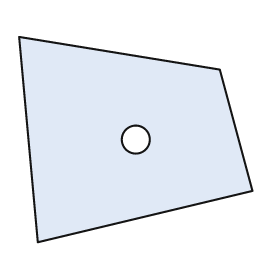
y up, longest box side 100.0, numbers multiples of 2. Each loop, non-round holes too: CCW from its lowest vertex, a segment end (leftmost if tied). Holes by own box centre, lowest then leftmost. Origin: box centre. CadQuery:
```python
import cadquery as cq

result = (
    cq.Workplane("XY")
    .moveTo(-42.0, -44.0)
    .lineTo(50.0, -22.0)
    .lineTo(36.0, 30.0)
    .lineTo(-50.0, 44.0)
    .close()
    .moveTo(0.0, 0.0)
    .circle(6.0)
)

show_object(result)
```